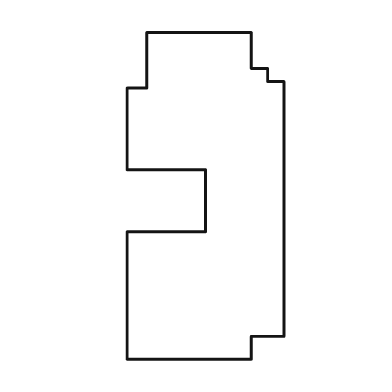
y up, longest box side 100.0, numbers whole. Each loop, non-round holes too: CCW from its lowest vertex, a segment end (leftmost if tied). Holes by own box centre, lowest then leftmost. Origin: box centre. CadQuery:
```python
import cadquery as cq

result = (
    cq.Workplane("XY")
    .moveTo(-24.0, -50.0)
    .lineTo(14.0, -50.0)
    .lineTo(14.0, -43.0)
    .lineTo(24.0, -43.0)
    .lineTo(24.0, 35.0)
    .lineTo(19.0, 35.0)
    .lineTo(19.0, 39.0)
    .lineTo(14.0, 39.0)
    .lineTo(14.0, 50.0)
    .lineTo(-18.0, 50.0)
    .lineTo(-18.0, 33.0)
    .lineTo(-24.0, 33.0)
    .lineTo(-24.0, 8.0)
    .lineTo(0.0, 8.0)
    .lineTo(0.0, -11.0)
    .lineTo(-24.0, -11.0)
    .close()
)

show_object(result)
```